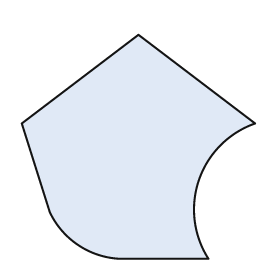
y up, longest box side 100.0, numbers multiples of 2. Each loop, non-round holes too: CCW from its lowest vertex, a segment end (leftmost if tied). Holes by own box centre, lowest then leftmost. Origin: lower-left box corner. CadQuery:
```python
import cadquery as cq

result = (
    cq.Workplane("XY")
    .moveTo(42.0, 0.0)
    .lineTo(80.0, 0.0)
    .threePointArc((76.0, 34.0), (100.0, 58.0))
    .lineTo(50.0, 96.0)
    .lineTo(0.0, 58.0)
    .lineTo(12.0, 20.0)
    .threePointArc((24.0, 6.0), (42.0, 0.0))
    .close()
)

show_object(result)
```